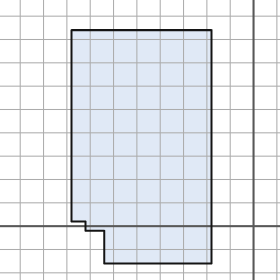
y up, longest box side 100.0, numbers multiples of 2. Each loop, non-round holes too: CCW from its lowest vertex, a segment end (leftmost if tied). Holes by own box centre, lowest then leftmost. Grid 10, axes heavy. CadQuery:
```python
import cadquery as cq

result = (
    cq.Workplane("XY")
    .moveTo(-64.0, -16.0)
    .lineTo(-18.0, -16.0)
    .lineTo(-18.0, 84.0)
    .lineTo(-78.0, 84.0)
    .lineTo(-78.0, 2.0)
    .lineTo(-72.0, 2.0)
    .lineTo(-72.0, -2.0)
    .lineTo(-64.0, -2.0)
    .close()
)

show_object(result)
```